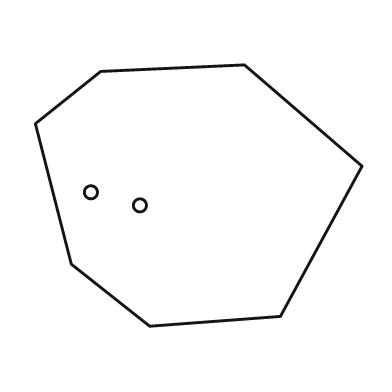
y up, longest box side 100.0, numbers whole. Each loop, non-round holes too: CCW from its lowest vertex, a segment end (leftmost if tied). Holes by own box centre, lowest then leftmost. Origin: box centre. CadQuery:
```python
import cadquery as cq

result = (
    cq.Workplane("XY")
    .moveTo(-15.0, -40.0)
    .lineTo(25.0, -37.0)
    .lineTo(50.0, 9.0)
    .lineTo(14.0, 40.0)
    .lineTo(-30.0, 38.0)
    .lineTo(-50.0, 22.0)
    .lineTo(-39.0, -21.0)
    .close()
    .moveTo(-18.0, -3.0)
    .circle(2.0)
    .moveTo(-33.0, 1.0)
    .circle(2.0)
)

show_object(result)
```